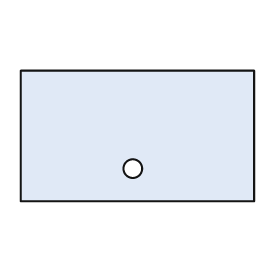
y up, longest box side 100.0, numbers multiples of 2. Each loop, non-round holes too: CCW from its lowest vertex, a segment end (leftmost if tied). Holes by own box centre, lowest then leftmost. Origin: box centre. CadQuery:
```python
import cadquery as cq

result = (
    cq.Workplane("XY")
    .moveTo(-50.0, -28.0)
    .lineTo(50.0, -28.0)
    .lineTo(50.0, 28.0)
    .lineTo(-50.0, 28.0)
    .close()
    .moveTo(-2.0, -14.0)
    .circle(4.0)
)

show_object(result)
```